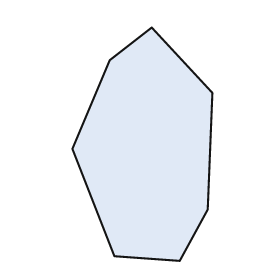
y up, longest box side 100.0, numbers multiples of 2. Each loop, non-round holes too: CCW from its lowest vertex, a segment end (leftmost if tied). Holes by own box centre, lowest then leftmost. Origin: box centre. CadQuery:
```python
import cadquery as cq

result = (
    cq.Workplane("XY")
    .moveTo(16.0, -50.0)
    .lineTo(28.0, -28.0)
    .lineTo(30.0, 22.0)
    .lineTo(4.0, 50.0)
    .lineTo(-14.0, 36.0)
    .lineTo(-30.0, -2.0)
    .lineTo(-12.0, -48.0)
    .close()
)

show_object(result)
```